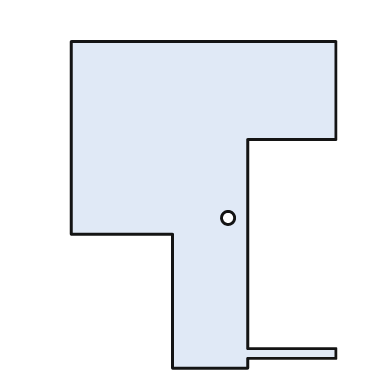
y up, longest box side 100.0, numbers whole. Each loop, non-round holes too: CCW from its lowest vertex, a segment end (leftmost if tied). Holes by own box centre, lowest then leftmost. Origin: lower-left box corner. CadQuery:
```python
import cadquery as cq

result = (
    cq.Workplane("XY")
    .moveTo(31.0, 0.0)
    .lineTo(54.0, 0.0)
    .lineTo(54.0, 3.0)
    .lineTo(81.0, 3.0)
    .lineTo(81.0, 6.0)
    .lineTo(54.0, 6.0)
    .lineTo(54.0, 70.0)
    .lineTo(81.0, 70.0)
    .lineTo(81.0, 100.0)
    .lineTo(0.0, 100.0)
    .lineTo(0.0, 41.0)
    .lineTo(31.0, 41.0)
    .close()
    .moveTo(48.0, 46.0)
    .circle(2.0)
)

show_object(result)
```